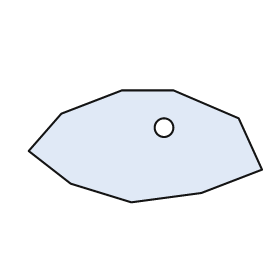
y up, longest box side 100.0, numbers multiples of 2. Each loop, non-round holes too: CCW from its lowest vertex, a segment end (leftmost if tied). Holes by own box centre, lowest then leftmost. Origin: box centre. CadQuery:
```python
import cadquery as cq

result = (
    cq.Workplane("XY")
    .moveTo(-6.0, -24.0)
    .lineTo(24.0, -20.0)
    .lineTo(50.0, -10.0)
    .lineTo(40.0, 12.0)
    .lineTo(12.0, 24.0)
    .lineTo(-10.0, 24.0)
    .lineTo(-36.0, 14.0)
    .lineTo(-50.0, -2.0)
    .lineTo(-32.0, -16.0)
    .close()
    .moveTo(8.0, 8.0)
    .circle(4.0)
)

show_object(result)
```